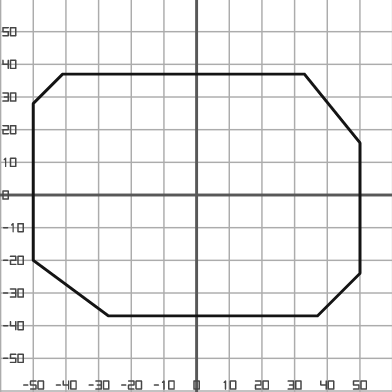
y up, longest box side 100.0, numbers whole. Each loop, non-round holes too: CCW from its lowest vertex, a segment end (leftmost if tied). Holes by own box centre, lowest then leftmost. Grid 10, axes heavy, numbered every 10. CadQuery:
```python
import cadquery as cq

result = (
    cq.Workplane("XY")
    .moveTo(-27.0, -37.0)
    .lineTo(37.0, -37.0)
    .lineTo(50.0, -24.0)
    .lineTo(50.0, 16.0)
    .lineTo(33.0, 37.0)
    .lineTo(-41.0, 37.0)
    .lineTo(-50.0, 28.0)
    .lineTo(-50.0, -20.0)
    .close()
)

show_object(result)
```